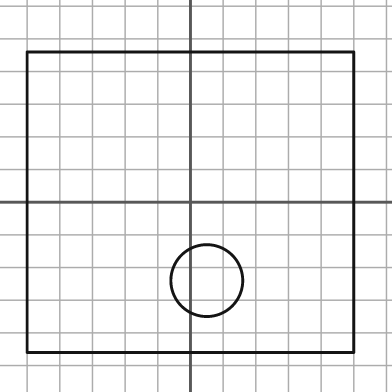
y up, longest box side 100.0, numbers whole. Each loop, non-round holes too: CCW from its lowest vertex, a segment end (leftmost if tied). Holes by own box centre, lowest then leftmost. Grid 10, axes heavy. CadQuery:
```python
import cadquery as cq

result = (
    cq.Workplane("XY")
    .moveTo(-50.0, -46.0)
    .lineTo(50.0, -46.0)
    .lineTo(50.0, 46.0)
    .lineTo(-50.0, 46.0)
    .close()
    .moveTo(5.0, -24.0)
    .circle(11.0)
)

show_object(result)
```